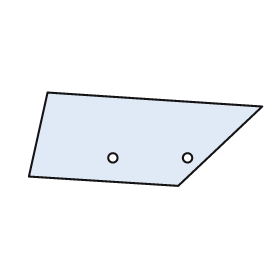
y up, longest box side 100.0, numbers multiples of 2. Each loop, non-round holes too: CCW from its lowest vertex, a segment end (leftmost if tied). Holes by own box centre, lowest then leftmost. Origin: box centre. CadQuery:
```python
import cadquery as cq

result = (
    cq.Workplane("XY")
    .moveTo(14.0, -20.0)
    .lineTo(50.0, 14.0)
    .lineTo(-42.0, 20.0)
    .lineTo(-50.0, -16.0)
    .close()
    .moveTo(-14.0, -8.0)
    .circle(2.0)
    .moveTo(18.0, -8.0)
    .circle(2.0)
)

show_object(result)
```